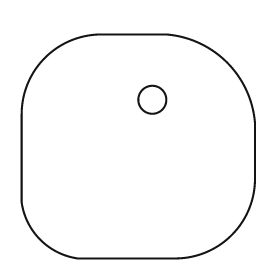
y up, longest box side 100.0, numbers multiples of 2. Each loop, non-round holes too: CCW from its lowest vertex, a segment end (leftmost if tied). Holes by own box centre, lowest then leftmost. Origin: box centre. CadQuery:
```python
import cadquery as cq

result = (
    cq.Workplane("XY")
    .moveTo(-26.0, -48.0)
    .lineTo(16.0, -48.0)
    .threePointArc((40.0, -38.0), (50.0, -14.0))
    .lineTo(50.0, 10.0)
    .threePointArc((38.0, 36.0), (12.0, 48.0))
    .lineTo(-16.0, 48.0)
    .threePointArc((-40.0, 38.0), (-50.0, 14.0))
    .lineTo(-50.0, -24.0)
    .threePointArc((-42.0, -40.0), (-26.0, -48.0))
    .close()
    .moveTo(6.0, 20.0)
    .circle(6.0)
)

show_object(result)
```